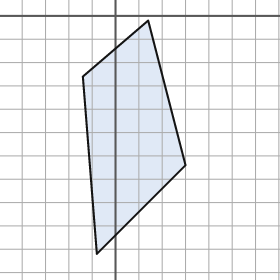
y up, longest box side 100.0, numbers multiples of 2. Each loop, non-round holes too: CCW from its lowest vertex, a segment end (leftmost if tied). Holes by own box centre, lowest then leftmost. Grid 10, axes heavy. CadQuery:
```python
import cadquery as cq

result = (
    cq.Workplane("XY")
    .moveTo(-8.0, -102.0)
    .lineTo(30.0, -64.0)
    .lineTo(14.0, -2.0)
    .lineTo(-14.0, -26.0)
    .close()
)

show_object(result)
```